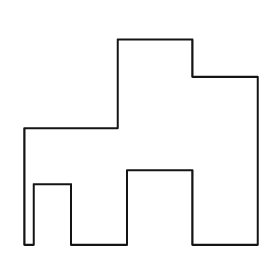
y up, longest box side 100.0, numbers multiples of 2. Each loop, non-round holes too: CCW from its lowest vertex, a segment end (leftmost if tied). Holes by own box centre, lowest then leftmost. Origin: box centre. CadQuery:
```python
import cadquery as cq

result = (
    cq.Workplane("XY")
    .moveTo(-50.0, -44.0)
    .lineTo(-46.0, -44.0)
    .lineTo(-46.0, -18.0)
    .lineTo(-30.0, -18.0)
    .lineTo(-30.0, -44.0)
    .lineTo(-6.0, -44.0)
    .lineTo(-6.0, -12.0)
    .lineTo(22.0, -12.0)
    .lineTo(22.0, -44.0)
    .lineTo(50.0, -44.0)
    .lineTo(50.0, 28.0)
    .lineTo(22.0, 28.0)
    .lineTo(22.0, 44.0)
    .lineTo(-10.0, 44.0)
    .lineTo(-10.0, 6.0)
    .lineTo(-50.0, 6.0)
    .close()
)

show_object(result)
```